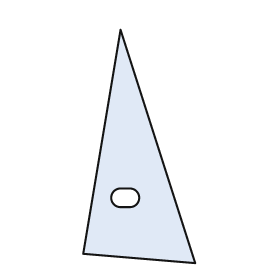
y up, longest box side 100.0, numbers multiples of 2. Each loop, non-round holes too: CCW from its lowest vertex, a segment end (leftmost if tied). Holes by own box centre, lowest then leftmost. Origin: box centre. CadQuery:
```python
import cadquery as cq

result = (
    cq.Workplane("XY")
    .moveTo(24.0, -50.0)
    .lineTo(-8.0, 50.0)
    .lineTo(-24.0, -46.0)
    .close()
    .moveTo(-8.0, -26.0)
    .lineTo(-4.0, -26.0)
    .threePointArc((0.0, -22.0), (-4.0, -18.0))
    .lineTo(-8.0, -18.0)
    .threePointArc((-12.0, -22.0), (-8.0, -26.0))
    .close()
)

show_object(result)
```